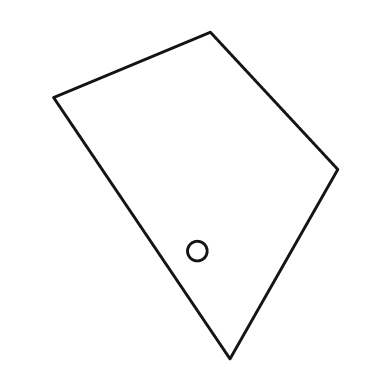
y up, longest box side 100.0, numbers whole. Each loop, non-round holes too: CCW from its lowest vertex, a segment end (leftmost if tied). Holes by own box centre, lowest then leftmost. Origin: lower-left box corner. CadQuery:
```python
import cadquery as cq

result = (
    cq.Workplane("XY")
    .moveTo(54.0, 0.0)
    .lineTo(87.0, 58.0)
    .lineTo(48.0, 100.0)
    .lineTo(0.0, 80.0)
    .close()
    .moveTo(44.0, 33.0)
    .circle(3.0)
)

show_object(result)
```